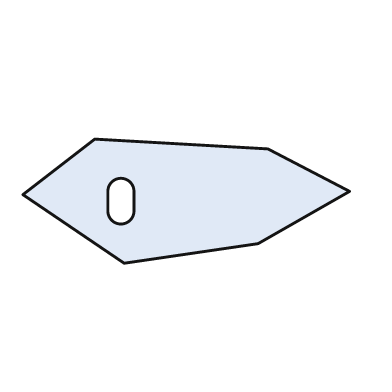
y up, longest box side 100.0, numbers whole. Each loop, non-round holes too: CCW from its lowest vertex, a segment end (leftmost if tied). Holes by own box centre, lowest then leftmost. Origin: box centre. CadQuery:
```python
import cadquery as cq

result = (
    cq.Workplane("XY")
    .moveTo(-19.0, -19.0)
    .lineTo(22.0, -13.0)
    .lineTo(50.0, 3.0)
    .lineTo(25.0, 16.0)
    .lineTo(-28.0, 19.0)
    .lineTo(-50.0, 2.0)
    .close()
    .moveTo(-24.0, -3.0)
    .threePointArc((-20.0, -7.0), (-16.0, -3.0))
    .lineTo(-16.0, 3.0)
    .threePointArc((-20.0, 7.0), (-24.0, 3.0))
    .close()
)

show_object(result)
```